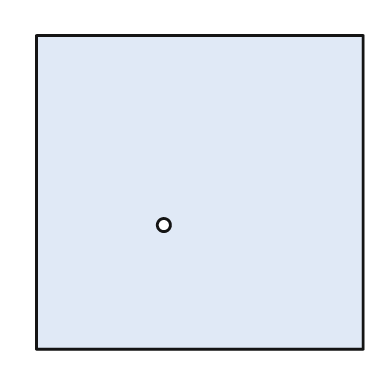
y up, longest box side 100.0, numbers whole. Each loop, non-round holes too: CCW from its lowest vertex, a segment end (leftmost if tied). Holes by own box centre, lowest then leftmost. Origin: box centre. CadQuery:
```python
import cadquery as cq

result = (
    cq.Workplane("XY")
    .moveTo(-50.0, -48.0)
    .lineTo(50.0, -48.0)
    .lineTo(50.0, 48.0)
    .lineTo(-50.0, 48.0)
    .close()
    .moveTo(-11.0, -10.0)
    .circle(2.0)
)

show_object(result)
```